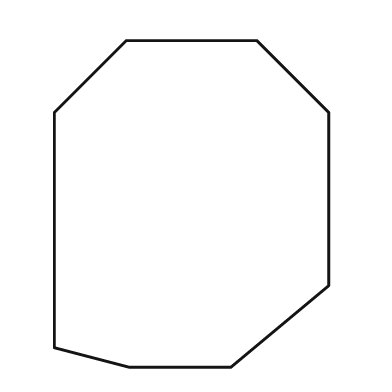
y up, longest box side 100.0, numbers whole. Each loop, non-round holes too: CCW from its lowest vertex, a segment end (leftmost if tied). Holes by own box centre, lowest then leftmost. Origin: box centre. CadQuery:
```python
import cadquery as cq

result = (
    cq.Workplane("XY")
    .moveTo(-19.0, -50.0)
    .lineTo(12.0, -50.0)
    .lineTo(42.0, -25.0)
    .lineTo(42.0, 28.0)
    .lineTo(20.0, 50.0)
    .lineTo(-20.0, 50.0)
    .lineTo(-42.0, 28.0)
    .lineTo(-42.0, -44.0)
    .close()
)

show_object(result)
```